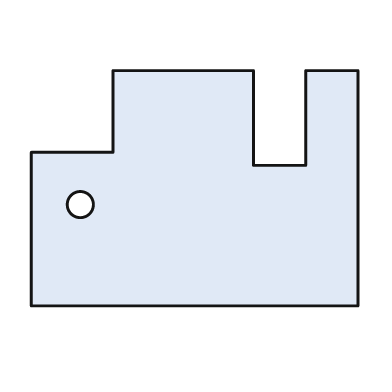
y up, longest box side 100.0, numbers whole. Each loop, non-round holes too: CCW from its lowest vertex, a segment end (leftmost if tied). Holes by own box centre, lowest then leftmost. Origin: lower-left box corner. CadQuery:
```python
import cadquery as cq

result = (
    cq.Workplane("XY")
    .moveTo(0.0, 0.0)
    .lineTo(100.0, 0.0)
    .lineTo(100.0, 72.0)
    .lineTo(84.0, 72.0)
    .lineTo(84.0, 43.0)
    .lineTo(68.0, 43.0)
    .lineTo(68.0, 72.0)
    .lineTo(25.0, 72.0)
    .lineTo(25.0, 47.0)
    .lineTo(0.0, 47.0)
    .close()
    .moveTo(15.0, 31.0)
    .circle(4.0)
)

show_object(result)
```